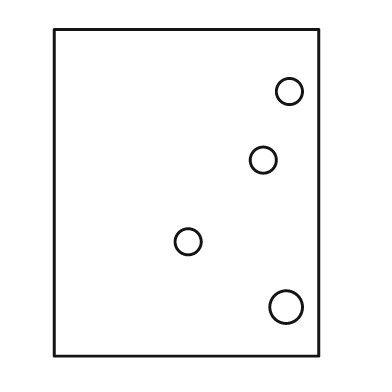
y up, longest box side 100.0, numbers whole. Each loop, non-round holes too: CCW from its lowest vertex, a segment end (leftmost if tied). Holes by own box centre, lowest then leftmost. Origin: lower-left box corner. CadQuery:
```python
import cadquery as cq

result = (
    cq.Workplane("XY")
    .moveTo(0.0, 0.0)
    .lineTo(81.0, 0.0)
    .lineTo(81.0, 100.0)
    .lineTo(0.0, 100.0)
    .close()
    .moveTo(71.0, 15.0)
    .circle(5.0)
    .moveTo(41.0, 35.0)
    .circle(4.0)
    .moveTo(64.0, 60.0)
    .circle(4.0)
    .moveTo(72.0, 81.0)
    .circle(4.0)
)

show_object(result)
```